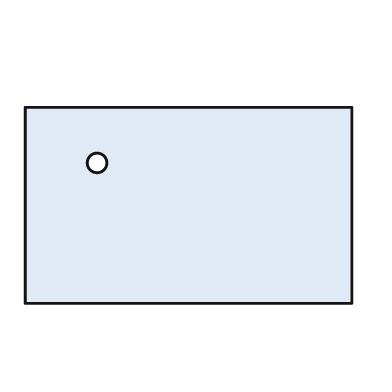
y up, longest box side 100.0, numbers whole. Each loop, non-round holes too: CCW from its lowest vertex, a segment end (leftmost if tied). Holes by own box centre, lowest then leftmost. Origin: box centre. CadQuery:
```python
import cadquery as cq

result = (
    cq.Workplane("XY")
    .moveTo(-50.0, -30.0)
    .lineTo(50.0, -30.0)
    .lineTo(50.0, 30.0)
    .lineTo(-50.0, 30.0)
    .close()
    .moveTo(-28.0, 13.0)
    .circle(3.0)
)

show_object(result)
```